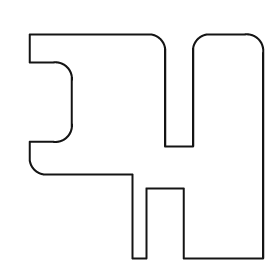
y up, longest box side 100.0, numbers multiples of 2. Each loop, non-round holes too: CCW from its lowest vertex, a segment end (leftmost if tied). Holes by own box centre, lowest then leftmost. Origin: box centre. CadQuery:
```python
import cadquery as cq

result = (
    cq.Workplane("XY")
    .moveTo(-6.0, -48.0)
    .lineTo(0.0, -48.0)
    .lineTo(0.0, -18.0)
    .lineTo(16.0, -18.0)
    .lineTo(16.0, -48.0)
    .lineTo(50.0, -48.0)
    .lineTo(50.0, 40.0)
    .threePointArc((48.0, 46.0), (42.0, 48.0))
    .lineTo(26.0, 48.0)
    .threePointArc((22.0, 46.0), (20.0, 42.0))
    .lineTo(20.0, 0.0)
    .lineTo(8.0, 0.0)
    .lineTo(8.0, 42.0)
    .threePointArc((6.0, 46.0), (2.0, 48.0))
    .lineTo(-50.0, 48.0)
    .lineTo(-50.0, 36.0)
    .lineTo(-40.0, 36.0)
    .threePointArc((-34.0, 34.0), (-32.0, 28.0))
    .lineTo(-32.0, 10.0)
    .threePointArc((-34.0, 4.0), (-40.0, 2.0))
    .lineTo(-50.0, 2.0)
    .lineTo(-50.0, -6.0)
    .threePointArc((-48.0, -10.0), (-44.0, -12.0))
    .lineTo(-6.0, -12.0)
    .close()
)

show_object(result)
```